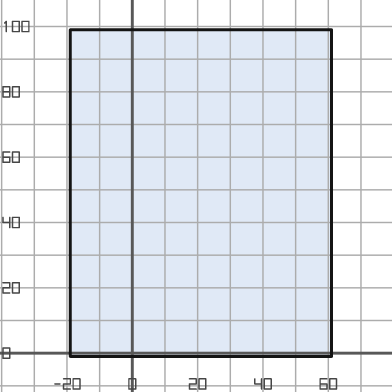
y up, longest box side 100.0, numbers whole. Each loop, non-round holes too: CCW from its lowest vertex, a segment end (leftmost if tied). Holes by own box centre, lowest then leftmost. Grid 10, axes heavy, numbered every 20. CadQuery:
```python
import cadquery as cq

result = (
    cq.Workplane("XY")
    .moveTo(-19.0, -1.0)
    .lineTo(61.0, -1.0)
    .lineTo(61.0, 99.0)
    .lineTo(-19.0, 99.0)
    .close()
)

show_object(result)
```